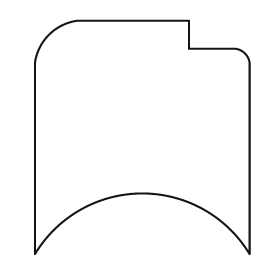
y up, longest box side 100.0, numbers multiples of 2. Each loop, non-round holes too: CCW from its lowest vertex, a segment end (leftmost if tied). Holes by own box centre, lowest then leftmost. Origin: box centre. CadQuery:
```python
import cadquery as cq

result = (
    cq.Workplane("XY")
    .moveTo(-46.0, -50.0)
    .threePointArc((0.0, -24.0), (46.0, -50.0))
    .lineTo(46.0, 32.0)
    .threePointArc((44.0, 36.0), (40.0, 38.0))
    .lineTo(20.0, 38.0)
    .lineTo(20.0, 50.0)
    .lineTo(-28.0, 50.0)
    .threePointArc((-40.0, 44.0), (-46.0, 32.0))
    .close()
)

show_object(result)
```